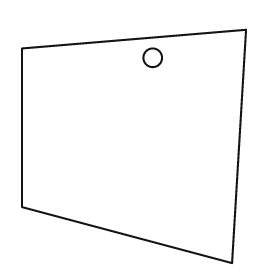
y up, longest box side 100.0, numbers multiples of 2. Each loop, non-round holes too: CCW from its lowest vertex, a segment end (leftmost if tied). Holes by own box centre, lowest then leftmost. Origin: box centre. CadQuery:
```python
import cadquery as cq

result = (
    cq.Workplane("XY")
    .moveTo(42.0, -50.0)
    .lineTo(48.0, 50.0)
    .lineTo(-48.0, 42.0)
    .lineTo(-48.0, -26.0)
    .close()
    .moveTo(8.0, 38.0)
    .circle(4.0)
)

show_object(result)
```